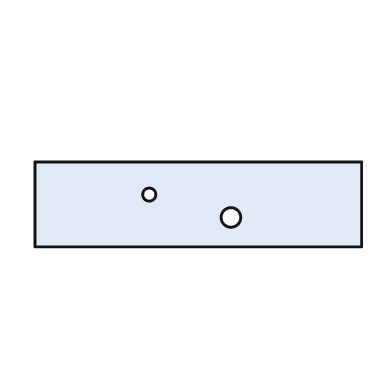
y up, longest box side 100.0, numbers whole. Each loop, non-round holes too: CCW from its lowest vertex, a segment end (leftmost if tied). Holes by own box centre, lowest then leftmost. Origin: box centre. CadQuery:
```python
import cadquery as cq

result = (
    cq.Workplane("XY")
    .moveTo(-50.0, -13.0)
    .lineTo(50.0, -13.0)
    .lineTo(50.0, 13.0)
    .lineTo(-50.0, 13.0)
    .close()
    .moveTo(10.0, -4.0)
    .circle(3.0)
    .moveTo(-15.0, 3.0)
    .circle(2.0)
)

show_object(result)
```